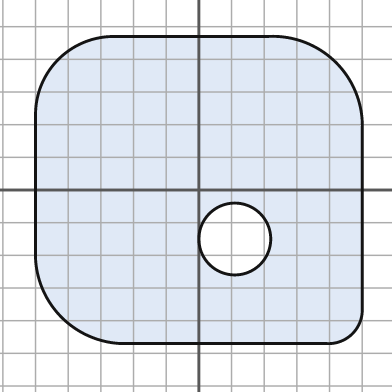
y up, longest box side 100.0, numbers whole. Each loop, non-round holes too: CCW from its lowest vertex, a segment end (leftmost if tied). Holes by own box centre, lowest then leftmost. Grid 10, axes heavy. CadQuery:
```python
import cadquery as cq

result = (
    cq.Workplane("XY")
    .moveTo(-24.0, -47.0)
    .lineTo(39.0, -47.0)
    .threePointArc((47.0, -44.0), (50.0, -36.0))
    .lineTo(50.0, 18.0)
    .threePointArc((42.0, 39.0), (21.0, 47.0))
    .lineTo(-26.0, 47.0)
    .threePointArc((-43.0, 40.0), (-50.0, 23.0))
    .lineTo(-50.0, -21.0)
    .threePointArc((-42.0, -39.0), (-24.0, -47.0))
    .close()
    .moveTo(11.0, -15.0)
    .circle(11.0)
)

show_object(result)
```